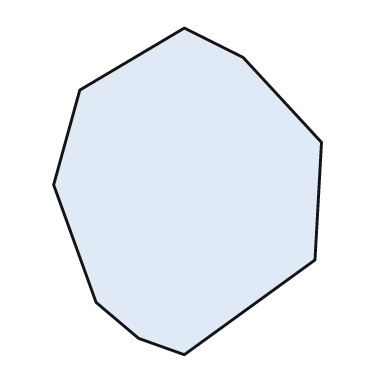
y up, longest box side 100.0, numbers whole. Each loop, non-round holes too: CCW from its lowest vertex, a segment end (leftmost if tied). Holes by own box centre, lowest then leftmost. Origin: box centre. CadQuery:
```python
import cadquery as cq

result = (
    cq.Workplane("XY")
    .moveTo(-1.0, -50.0)
    .lineTo(39.0, -21.0)
    .lineTo(41.0, 15.0)
    .lineTo(17.0, 41.0)
    .lineTo(-1.0, 50.0)
    .lineTo(-33.0, 31.0)
    .lineTo(-41.0, 2.0)
    .lineTo(-28.0, -34.0)
    .lineTo(-15.0, -45.0)
    .close()
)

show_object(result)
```